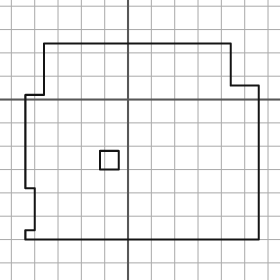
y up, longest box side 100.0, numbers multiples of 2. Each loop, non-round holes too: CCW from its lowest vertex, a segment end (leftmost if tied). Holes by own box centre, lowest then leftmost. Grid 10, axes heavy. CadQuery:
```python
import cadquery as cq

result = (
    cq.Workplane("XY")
    .moveTo(-44.0, -60.0)
    .lineTo(56.0, -60.0)
    .lineTo(56.0, 6.0)
    .lineTo(44.0, 6.0)
    .lineTo(44.0, 24.0)
    .lineTo(-36.0, 24.0)
    .lineTo(-36.0, 2.0)
    .lineTo(-44.0, 2.0)
    .lineTo(-44.0, -38.0)
    .lineTo(-40.0, -38.0)
    .lineTo(-40.0, -56.0)
    .lineTo(-44.0, -56.0)
    .close()
    .moveTo(-12.0, -30.0)
    .lineTo(-4.0, -30.0)
    .lineTo(-4.0, -22.0)
    .lineTo(-12.0, -22.0)
    .close()
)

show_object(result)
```